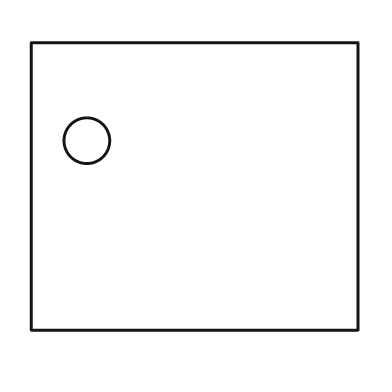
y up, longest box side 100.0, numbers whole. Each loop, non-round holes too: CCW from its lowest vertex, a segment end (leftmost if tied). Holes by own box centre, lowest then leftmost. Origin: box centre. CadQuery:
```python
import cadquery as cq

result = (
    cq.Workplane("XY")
    .moveTo(-50.0, -44.0)
    .lineTo(50.0, -44.0)
    .lineTo(50.0, 44.0)
    .lineTo(-50.0, 44.0)
    .close()
    .moveTo(-33.0, 14.0)
    .circle(7.0)
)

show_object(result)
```